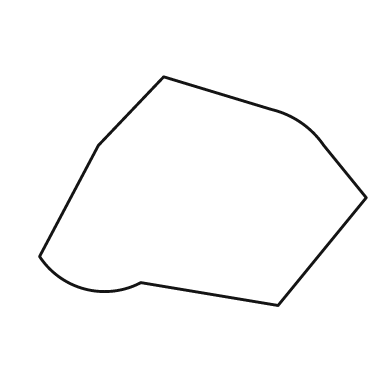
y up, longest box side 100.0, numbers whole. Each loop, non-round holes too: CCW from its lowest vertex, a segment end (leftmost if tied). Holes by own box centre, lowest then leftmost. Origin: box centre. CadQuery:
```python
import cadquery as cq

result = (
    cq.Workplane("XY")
    .moveTo(23.0, -35.0)
    .lineTo(50.0, -2.0)
    .lineTo(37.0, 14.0)
    .threePointArc((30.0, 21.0), (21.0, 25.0))
    .lineTo(-12.0, 35.0)
    .lineTo(-32.0, 14.0)
    .lineTo(-50.0, -20.0)
    .threePointArc((-36.0, -30.0), (-19.0, -28.0))
    .close()
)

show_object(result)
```